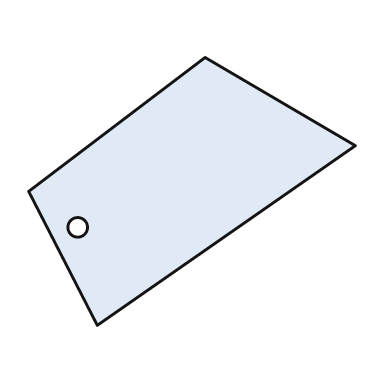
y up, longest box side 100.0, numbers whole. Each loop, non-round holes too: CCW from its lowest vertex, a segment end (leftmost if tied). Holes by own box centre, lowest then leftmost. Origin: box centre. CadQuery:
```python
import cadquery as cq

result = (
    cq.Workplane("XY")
    .moveTo(-29.0, -41.0)
    .lineTo(50.0, 14.0)
    .lineTo(4.0, 41.0)
    .lineTo(-50.0, 0.0)
    .close()
    .moveTo(-35.0, -11.0)
    .circle(3.0)
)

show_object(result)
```